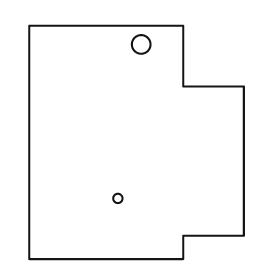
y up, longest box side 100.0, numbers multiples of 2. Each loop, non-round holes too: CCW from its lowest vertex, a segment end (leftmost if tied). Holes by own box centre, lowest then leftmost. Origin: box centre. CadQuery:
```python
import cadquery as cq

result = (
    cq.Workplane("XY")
    .moveTo(-46.0, -50.0)
    .lineTo(20.0, -50.0)
    .lineTo(20.0, -40.0)
    .lineTo(46.0, -40.0)
    .lineTo(46.0, 24.0)
    .lineTo(20.0, 24.0)
    .lineTo(20.0, 50.0)
    .lineTo(-46.0, 50.0)
    .close()
    .moveTo(-8.0, -24.0)
    .circle(2.0)
    .moveTo(2.0, 42.0)
    .circle(4.0)
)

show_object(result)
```